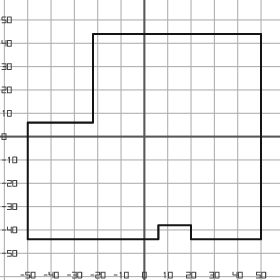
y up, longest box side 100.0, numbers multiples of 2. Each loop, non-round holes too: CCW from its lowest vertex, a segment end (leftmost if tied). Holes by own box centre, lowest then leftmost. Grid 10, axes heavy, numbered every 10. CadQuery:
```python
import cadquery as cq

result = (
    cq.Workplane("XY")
    .moveTo(-50.0, -44.0)
    .lineTo(6.0, -44.0)
    .lineTo(6.0, -38.0)
    .lineTo(20.0, -38.0)
    .lineTo(20.0, -44.0)
    .lineTo(50.0, -44.0)
    .lineTo(50.0, 44.0)
    .lineTo(-22.0, 44.0)
    .lineTo(-22.0, 6.0)
    .lineTo(-50.0, 6.0)
    .close()
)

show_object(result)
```